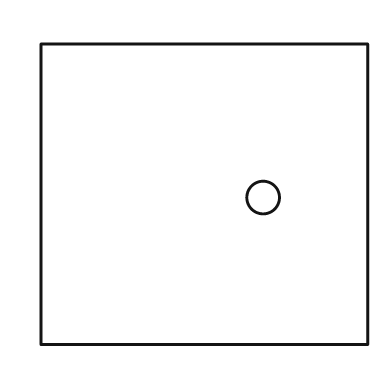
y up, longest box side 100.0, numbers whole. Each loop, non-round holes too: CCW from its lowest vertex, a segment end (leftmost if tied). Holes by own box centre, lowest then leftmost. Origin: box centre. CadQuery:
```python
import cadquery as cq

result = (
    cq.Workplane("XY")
    .moveTo(-50.0, -46.0)
    .lineTo(50.0, -46.0)
    .lineTo(50.0, 46.0)
    .lineTo(-50.0, 46.0)
    .close()
    .moveTo(18.0, -1.0)
    .circle(5.0)
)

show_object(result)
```